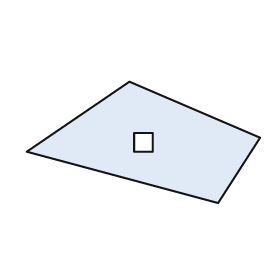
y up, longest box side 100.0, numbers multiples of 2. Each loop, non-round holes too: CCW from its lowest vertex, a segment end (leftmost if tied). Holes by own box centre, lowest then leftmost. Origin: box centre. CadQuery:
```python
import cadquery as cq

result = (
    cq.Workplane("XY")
    .moveTo(32.0, -26.0)
    .lineTo(50.0, 2.0)
    .lineTo(-6.0, 26.0)
    .lineTo(-50.0, -4.0)
    .close()
    .moveTo(-4.0, -4.0)
    .lineTo(4.0, -4.0)
    .lineTo(4.0, 4.0)
    .lineTo(-4.0, 4.0)
    .close()
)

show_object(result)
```